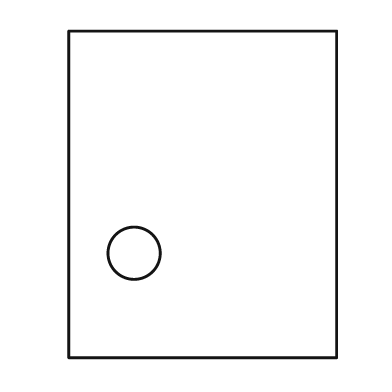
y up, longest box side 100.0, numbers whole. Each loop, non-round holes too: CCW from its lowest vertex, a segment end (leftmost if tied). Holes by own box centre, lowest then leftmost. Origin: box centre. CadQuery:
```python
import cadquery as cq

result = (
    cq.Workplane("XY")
    .moveTo(-41.0, -50.0)
    .lineTo(41.0, -50.0)
    .lineTo(41.0, 50.0)
    .lineTo(-41.0, 50.0)
    .close()
    .moveTo(-21.0, -18.0)
    .circle(8.0)
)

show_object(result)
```